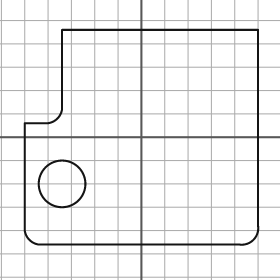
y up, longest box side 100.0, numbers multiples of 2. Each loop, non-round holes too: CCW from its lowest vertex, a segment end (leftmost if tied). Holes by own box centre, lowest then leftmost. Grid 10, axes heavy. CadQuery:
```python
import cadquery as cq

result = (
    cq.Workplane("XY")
    .moveTo(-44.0, -46.0)
    .lineTo(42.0, -46.0)
    .threePointArc((48.0, -44.0), (50.0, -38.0))
    .lineTo(50.0, 46.0)
    .lineTo(-34.0, 46.0)
    .lineTo(-34.0, 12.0)
    .threePointArc((-36.0, 8.0), (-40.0, 6.0))
    .lineTo(-50.0, 6.0)
    .lineTo(-50.0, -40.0)
    .threePointArc((-48.0, -44.0), (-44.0, -46.0))
    .close()
    .moveTo(-34.0, -20.0)
    .circle(10.0)
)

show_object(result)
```